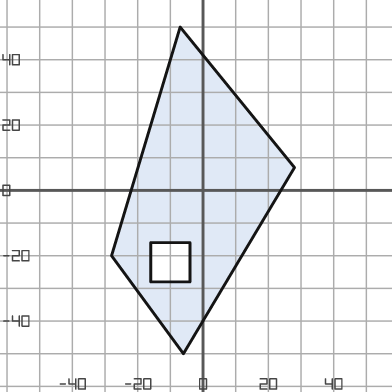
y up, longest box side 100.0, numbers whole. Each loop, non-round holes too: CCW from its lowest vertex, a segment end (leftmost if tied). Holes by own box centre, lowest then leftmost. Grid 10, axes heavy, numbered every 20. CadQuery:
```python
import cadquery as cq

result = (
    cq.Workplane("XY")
    .moveTo(-6.0, -50.0)
    .lineTo(28.0, 7.0)
    .lineTo(-7.0, 50.0)
    .lineTo(-28.0, -20.0)
    .close()
    .moveTo(-16.0, -28.0)
    .lineTo(-4.0, -28.0)
    .lineTo(-4.0, -16.0)
    .lineTo(-16.0, -16.0)
    .close()
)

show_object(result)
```